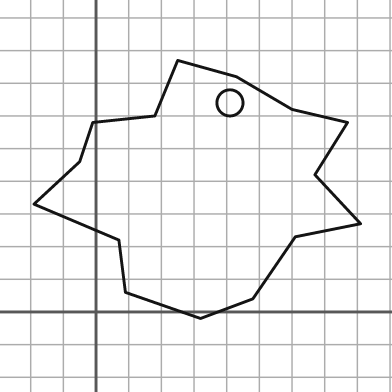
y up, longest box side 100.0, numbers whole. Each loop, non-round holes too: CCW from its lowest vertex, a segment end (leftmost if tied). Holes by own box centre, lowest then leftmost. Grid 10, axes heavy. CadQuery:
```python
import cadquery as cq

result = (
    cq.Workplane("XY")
    .moveTo(32.0, -2.0)
    .lineTo(48.0, 4.0)
    .lineTo(61.0, 23.0)
    .lineTo(81.0, 27.0)
    .lineTo(67.0, 42.0)
    .lineTo(77.0, 58.0)
    .lineTo(60.0, 62.0)
    .lineTo(43.0, 72.0)
    .lineTo(25.0, 77.0)
    .lineTo(18.0, 60.0)
    .lineTo(-1.0, 58.0)
    .lineTo(-5.0, 46.0)
    .lineTo(-19.0, 33.0)
    .lineTo(7.0, 22.0)
    .lineTo(9.0, 6.0)
    .close()
    .moveTo(41.0, 64.0)
    .circle(4.0)
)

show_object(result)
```